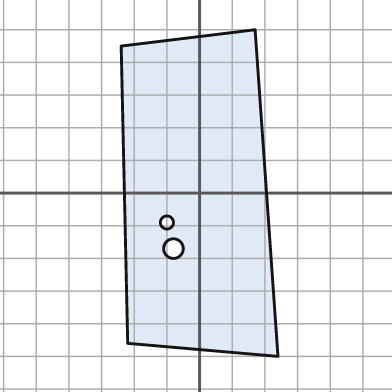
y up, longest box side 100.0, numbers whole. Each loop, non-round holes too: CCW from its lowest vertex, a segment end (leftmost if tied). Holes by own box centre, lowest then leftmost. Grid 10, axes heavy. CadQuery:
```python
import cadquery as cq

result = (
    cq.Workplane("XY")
    .moveTo(24.0, -50.0)
    .lineTo(17.0, 50.0)
    .lineTo(-24.0, 45.0)
    .lineTo(-22.0, -46.0)
    .close()
    .moveTo(-8.0, -17.0)
    .circle(3.0)
    .moveTo(-10.0, -9.0)
    .circle(2.0)
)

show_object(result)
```